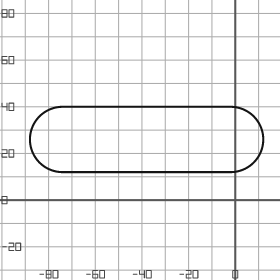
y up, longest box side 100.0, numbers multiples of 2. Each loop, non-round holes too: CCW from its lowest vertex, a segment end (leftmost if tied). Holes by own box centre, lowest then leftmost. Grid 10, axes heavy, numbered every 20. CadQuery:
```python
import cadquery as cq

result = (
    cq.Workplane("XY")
    .moveTo(-74.0, 12.0)
    .lineTo(-2.0, 12.0)
    .threePointArc((12.0, 26.0), (-2.0, 40.0))
    .lineTo(-74.0, 40.0)
    .threePointArc((-88.0, 26.0), (-74.0, 12.0))
    .close()
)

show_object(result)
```